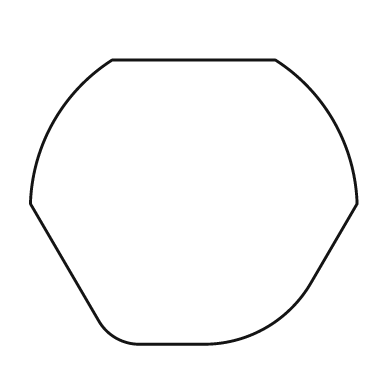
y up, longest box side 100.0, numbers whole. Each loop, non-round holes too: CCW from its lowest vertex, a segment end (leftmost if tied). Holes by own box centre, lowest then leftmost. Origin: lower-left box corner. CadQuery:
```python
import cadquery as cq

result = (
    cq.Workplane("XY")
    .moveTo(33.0, 0.0)
    .lineTo(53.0, 0.0)
    .threePointArc((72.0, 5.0), (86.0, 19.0))
    .lineTo(100.0, 43.0)
    .threePointArc((93.0, 68.0), (75.0, 87.0))
    .lineTo(25.0, 87.0)
    .threePointArc((7.0, 68.0), (0.0, 43.0))
    .lineTo(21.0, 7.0)
    .threePointArc((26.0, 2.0), (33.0, 0.0))
    .close()
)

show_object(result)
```